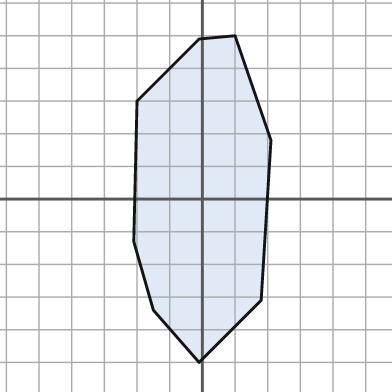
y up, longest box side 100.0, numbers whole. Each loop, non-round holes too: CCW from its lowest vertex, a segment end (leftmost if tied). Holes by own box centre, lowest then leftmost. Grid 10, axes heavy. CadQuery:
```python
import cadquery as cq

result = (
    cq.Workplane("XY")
    .moveTo(-1.0, -50.0)
    .lineTo(18.0, -31.0)
    .lineTo(21.0, 18.0)
    .lineTo(10.0, 50.0)
    .lineTo(-1.0, 49.0)
    .lineTo(-20.0, 30.0)
    .lineTo(-21.0, -13.0)
    .lineTo(-15.0, -34.0)
    .close()
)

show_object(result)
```